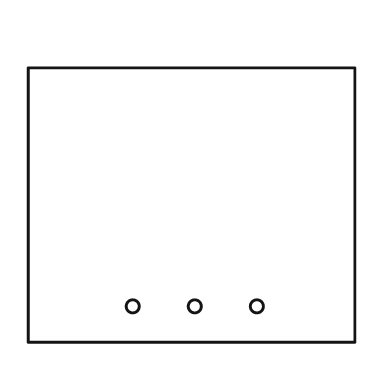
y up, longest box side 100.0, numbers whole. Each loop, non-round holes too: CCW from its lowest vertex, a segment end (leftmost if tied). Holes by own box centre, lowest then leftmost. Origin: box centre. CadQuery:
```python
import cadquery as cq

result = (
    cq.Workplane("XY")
    .moveTo(-50.0, -42.0)
    .lineTo(50.0, -42.0)
    .lineTo(50.0, 42.0)
    .lineTo(-50.0, 42.0)
    .close()
    .moveTo(-18.0, -31.0)
    .circle(2.0)
    .moveTo(1.0, -31.0)
    .circle(2.0)
    .moveTo(20.0, -31.0)
    .circle(2.0)
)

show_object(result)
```